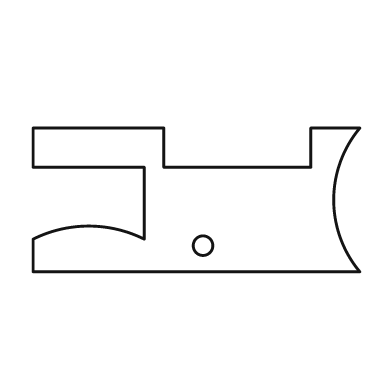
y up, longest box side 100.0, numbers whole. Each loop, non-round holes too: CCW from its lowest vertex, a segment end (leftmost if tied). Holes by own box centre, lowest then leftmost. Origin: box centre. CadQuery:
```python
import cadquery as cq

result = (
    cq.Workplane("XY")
    .moveTo(-50.0, -22.0)
    .lineTo(50.0, -22.0)
    .threePointArc((42.0, 0.0), (50.0, 22.0))
    .lineTo(35.0, 22.0)
    .lineTo(35.0, 10.0)
    .lineTo(-10.0, 10.0)
    .lineTo(-10.0, 22.0)
    .lineTo(-50.0, 22.0)
    .lineTo(-50.0, 10.0)
    .lineTo(-16.0, 10.0)
    .lineTo(-16.0, -12.0)
    .threePointArc((-33.0, -8.0), (-50.0, -12.0))
    .close()
    .moveTo(2.0, -14.0)
    .circle(3.0)
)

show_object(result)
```